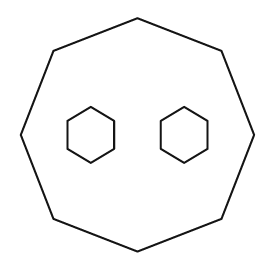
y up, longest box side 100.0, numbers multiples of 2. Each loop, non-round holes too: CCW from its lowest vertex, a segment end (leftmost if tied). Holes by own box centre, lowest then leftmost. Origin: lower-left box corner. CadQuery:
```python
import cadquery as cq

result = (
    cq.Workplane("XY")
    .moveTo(50.0, 0.0)
    .lineTo(86.0, 14.0)
    .lineTo(100.0, 50.0)
    .lineTo(86.0, 86.0)
    .lineTo(50.0, 100.0)
    .lineTo(14.0, 86.0)
    .lineTo(0.0, 50.0)
    .lineTo(14.0, 14.0)
    .close()
    .moveTo(30.0, 38.0)
    .lineTo(40.0, 44.0)
    .lineTo(40.0, 56.0)
    .lineTo(30.0, 62.0)
    .lineTo(20.0, 56.0)
    .lineTo(20.0, 44.0)
    .close()
    .moveTo(70.0, 38.0)
    .lineTo(80.0, 44.0)
    .lineTo(80.0, 56.0)
    .lineTo(70.0, 62.0)
    .lineTo(60.0, 56.0)
    .lineTo(60.0, 44.0)
    .close()
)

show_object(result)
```